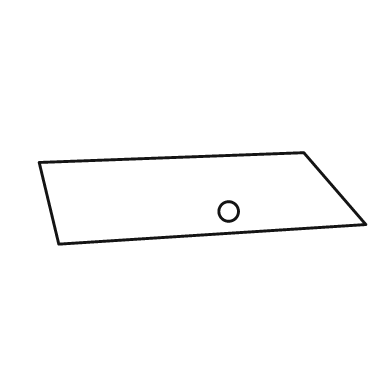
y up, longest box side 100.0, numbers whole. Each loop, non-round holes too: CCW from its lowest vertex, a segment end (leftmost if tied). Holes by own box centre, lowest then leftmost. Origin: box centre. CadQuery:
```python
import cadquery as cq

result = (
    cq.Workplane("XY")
    .moveTo(-44.0, -14.0)
    .lineTo(50.0, -8.0)
    .lineTo(31.0, 14.0)
    .lineTo(-50.0, 11.0)
    .close()
    .moveTo(8.0, -4.0)
    .circle(3.0)
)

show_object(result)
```